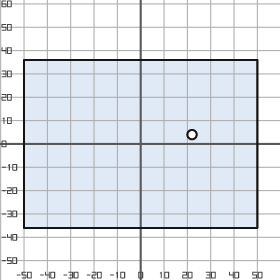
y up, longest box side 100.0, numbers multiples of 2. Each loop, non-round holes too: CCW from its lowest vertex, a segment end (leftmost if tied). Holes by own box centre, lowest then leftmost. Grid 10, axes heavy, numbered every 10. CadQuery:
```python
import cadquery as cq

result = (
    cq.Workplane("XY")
    .moveTo(-50.0, -36.0)
    .lineTo(50.0, -36.0)
    .lineTo(50.0, 36.0)
    .lineTo(-50.0, 36.0)
    .close()
    .moveTo(22.0, 4.0)
    .circle(2.0)
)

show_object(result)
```